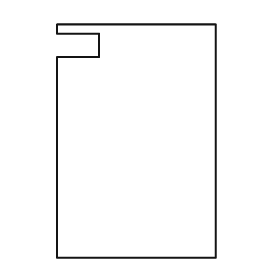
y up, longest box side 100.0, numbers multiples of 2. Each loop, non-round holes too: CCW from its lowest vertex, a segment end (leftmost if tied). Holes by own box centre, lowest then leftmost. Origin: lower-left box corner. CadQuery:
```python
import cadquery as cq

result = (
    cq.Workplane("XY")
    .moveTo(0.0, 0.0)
    .lineTo(68.0, 0.0)
    .lineTo(68.0, 100.0)
    .lineTo(0.0, 100.0)
    .lineTo(0.0, 96.0)
    .lineTo(18.0, 96.0)
    .lineTo(18.0, 86.0)
    .lineTo(0.0, 86.0)
    .close()
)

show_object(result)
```